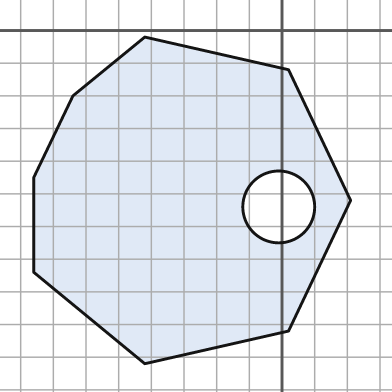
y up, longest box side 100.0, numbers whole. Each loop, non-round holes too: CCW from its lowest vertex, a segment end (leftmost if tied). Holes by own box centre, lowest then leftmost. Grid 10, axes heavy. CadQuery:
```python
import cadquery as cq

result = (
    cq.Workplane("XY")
    .moveTo(-42.0, -102.0)
    .lineTo(2.0, -92.0)
    .lineTo(21.0, -52.0)
    .lineTo(2.0, -12.0)
    .lineTo(-42.0, -2.0)
    .lineTo(-64.0, -20.0)
    .lineTo(-76.0, -45.0)
    .lineTo(-76.0, -74.0)
    .close()
    .moveTo(-1.0, -54.0)
    .circle(11.0)
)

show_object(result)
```